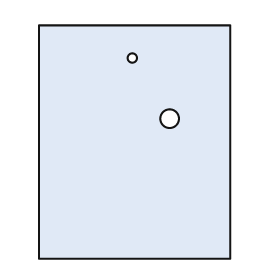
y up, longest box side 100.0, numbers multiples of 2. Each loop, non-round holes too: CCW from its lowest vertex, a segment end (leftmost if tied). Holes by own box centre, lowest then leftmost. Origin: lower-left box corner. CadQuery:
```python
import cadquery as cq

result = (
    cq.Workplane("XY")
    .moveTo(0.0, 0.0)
    .lineTo(82.0, 0.0)
    .lineTo(82.0, 100.0)
    .lineTo(0.0, 100.0)
    .close()
    .moveTo(56.0, 60.0)
    .circle(4.0)
    .moveTo(40.0, 86.0)
    .circle(2.0)
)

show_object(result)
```